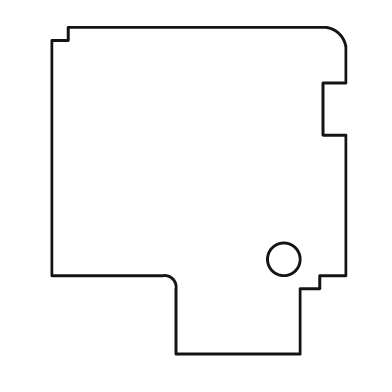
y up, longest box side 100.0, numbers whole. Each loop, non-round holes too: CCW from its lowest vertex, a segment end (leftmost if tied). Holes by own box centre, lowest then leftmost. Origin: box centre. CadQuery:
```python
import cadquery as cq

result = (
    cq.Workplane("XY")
    .moveTo(-7.0, -50.0)
    .lineTo(31.0, -50.0)
    .lineTo(31.0, -30.0)
    .lineTo(37.0, -30.0)
    .lineTo(37.0, -26.0)
    .lineTo(45.0, -26.0)
    .lineTo(45.0, 17.0)
    .lineTo(38.0, 17.0)
    .lineTo(38.0, 33.0)
    .lineTo(45.0, 33.0)
    .lineTo(45.0, 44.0)
    .threePointArc((43.0, 48.0), (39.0, 50.0))
    .lineTo(-40.0, 50.0)
    .lineTo(-40.0, 46.0)
    .lineTo(-45.0, 46.0)
    .lineTo(-45.0, -26.0)
    .lineTo(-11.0, -26.0)
    .threePointArc((-8.0, -27.0), (-7.0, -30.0))
    .close()
    .moveTo(26.0, -21.0)
    .circle(5.0)
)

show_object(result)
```